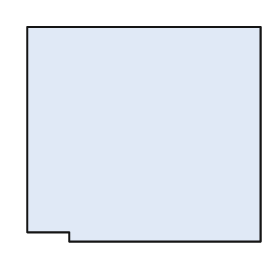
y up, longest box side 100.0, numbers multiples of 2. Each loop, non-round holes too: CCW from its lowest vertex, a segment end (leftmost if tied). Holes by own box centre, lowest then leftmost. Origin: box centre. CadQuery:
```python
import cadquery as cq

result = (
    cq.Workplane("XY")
    .moveTo(-32.0, -46.0)
    .lineTo(50.0, -46.0)
    .lineTo(50.0, 46.0)
    .lineTo(-50.0, 46.0)
    .lineTo(-50.0, -42.0)
    .lineTo(-32.0, -42.0)
    .close()
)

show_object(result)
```